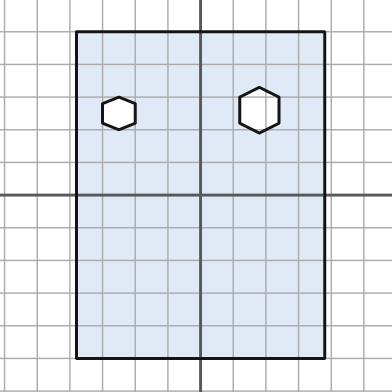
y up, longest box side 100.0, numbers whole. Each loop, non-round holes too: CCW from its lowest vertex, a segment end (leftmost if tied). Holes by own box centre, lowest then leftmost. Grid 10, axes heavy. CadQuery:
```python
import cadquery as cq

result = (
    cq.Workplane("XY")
    .moveTo(-38.0, -50.0)
    .lineTo(38.0, -50.0)
    .lineTo(38.0, 50.0)
    .lineTo(-38.0, 50.0)
    .close()
    .moveTo(-25.0, 20.0)
    .lineTo(-20.0, 22.0)
    .lineTo(-20.0, 28.0)
    .lineTo(-25.0, 30.0)
    .lineTo(-30.0, 28.0)
    .lineTo(-30.0, 22.0)
    .close()
    .moveTo(18.0, 19.0)
    .lineTo(24.0, 22.0)
    .lineTo(24.0, 30.0)
    .lineTo(18.0, 33.0)
    .lineTo(12.0, 30.0)
    .lineTo(12.0, 22.0)
    .close()
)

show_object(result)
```